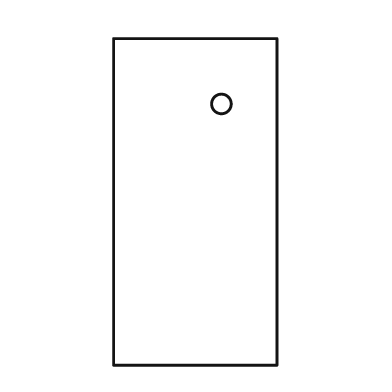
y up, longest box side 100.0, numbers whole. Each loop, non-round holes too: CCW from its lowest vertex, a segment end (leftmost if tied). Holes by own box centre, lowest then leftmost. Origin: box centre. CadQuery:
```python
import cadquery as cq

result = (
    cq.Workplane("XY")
    .moveTo(-25.0, -50.0)
    .lineTo(25.0, -50.0)
    .lineTo(25.0, 50.0)
    .lineTo(-25.0, 50.0)
    .close()
    .moveTo(8.0, 30.0)
    .circle(3.0)
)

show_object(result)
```